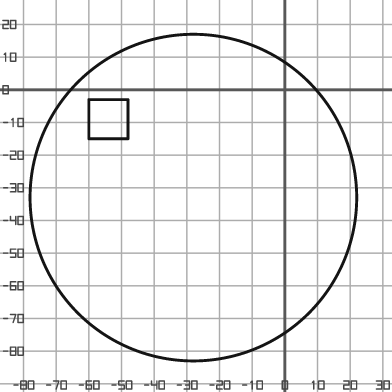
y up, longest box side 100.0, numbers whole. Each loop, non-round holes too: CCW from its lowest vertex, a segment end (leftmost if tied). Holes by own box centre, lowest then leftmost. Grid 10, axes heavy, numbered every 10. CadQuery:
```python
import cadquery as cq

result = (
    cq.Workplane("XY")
    .moveTo(-28.0, -33.0)
    .circle(50.0)
    .moveTo(-60.0, -15.0)
    .lineTo(-48.0, -15.0)
    .lineTo(-48.0, -3.0)
    .lineTo(-60.0, -3.0)
    .close()
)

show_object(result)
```